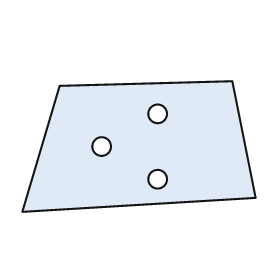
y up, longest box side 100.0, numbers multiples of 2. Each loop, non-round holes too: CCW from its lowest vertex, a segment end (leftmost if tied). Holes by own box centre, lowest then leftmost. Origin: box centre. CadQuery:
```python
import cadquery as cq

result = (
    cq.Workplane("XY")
    .moveTo(-50.0, -28.0)
    .lineTo(50.0, -22.0)
    .lineTo(40.0, 28.0)
    .lineTo(-34.0, 26.0)
    .close()
    .moveTo(8.0, -14.0)
    .circle(4.0)
    .moveTo(-16.0, 0.0)
    .circle(4.0)
    .moveTo(8.0, 14.0)
    .circle(4.0)
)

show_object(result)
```